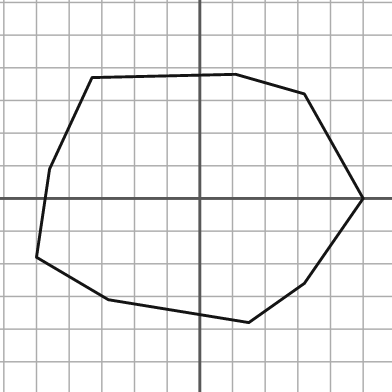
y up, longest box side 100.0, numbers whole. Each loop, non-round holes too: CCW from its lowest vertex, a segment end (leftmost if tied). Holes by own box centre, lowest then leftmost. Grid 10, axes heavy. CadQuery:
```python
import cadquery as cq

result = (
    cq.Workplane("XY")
    .moveTo(15.0, -38.0)
    .lineTo(32.0, -26.0)
    .lineTo(50.0, 0.0)
    .lineTo(32.0, 32.0)
    .lineTo(11.0, 38.0)
    .lineTo(-33.0, 37.0)
    .lineTo(-46.0, 9.0)
    .lineTo(-50.0, -18.0)
    .lineTo(-28.0, -31.0)
    .close()
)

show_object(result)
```